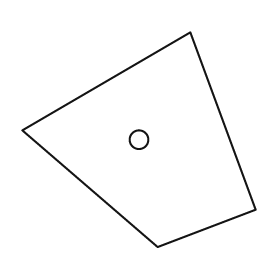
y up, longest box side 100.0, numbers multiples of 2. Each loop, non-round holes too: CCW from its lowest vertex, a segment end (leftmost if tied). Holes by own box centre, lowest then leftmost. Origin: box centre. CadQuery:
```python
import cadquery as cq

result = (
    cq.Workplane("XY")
    .moveTo(8.0, -46.0)
    .lineTo(50.0, -30.0)
    .lineTo(22.0, 46.0)
    .lineTo(-50.0, 4.0)
    .close()
    .moveTo(0.0, 0.0)
    .circle(4.0)
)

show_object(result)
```